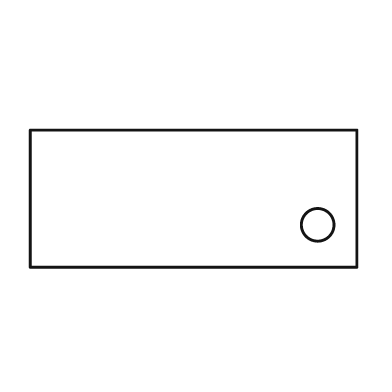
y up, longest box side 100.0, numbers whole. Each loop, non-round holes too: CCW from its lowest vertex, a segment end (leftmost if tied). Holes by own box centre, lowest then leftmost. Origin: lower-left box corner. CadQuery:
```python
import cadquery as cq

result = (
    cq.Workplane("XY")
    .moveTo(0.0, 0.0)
    .lineTo(100.0, 0.0)
    .lineTo(100.0, 42.0)
    .lineTo(0.0, 42.0)
    .close()
    .moveTo(88.0, 13.0)
    .circle(5.0)
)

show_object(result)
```